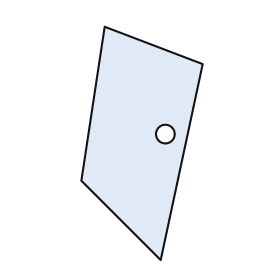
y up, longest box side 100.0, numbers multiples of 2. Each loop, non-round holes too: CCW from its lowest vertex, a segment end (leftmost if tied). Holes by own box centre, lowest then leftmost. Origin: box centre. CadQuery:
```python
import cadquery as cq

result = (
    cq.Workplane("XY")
    .moveTo(8.0, -50.0)
    .lineTo(26.0, 34.0)
    .lineTo(-16.0, 50.0)
    .lineTo(-26.0, -16.0)
    .close()
    .moveTo(10.0, 4.0)
    .circle(4.0)
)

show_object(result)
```